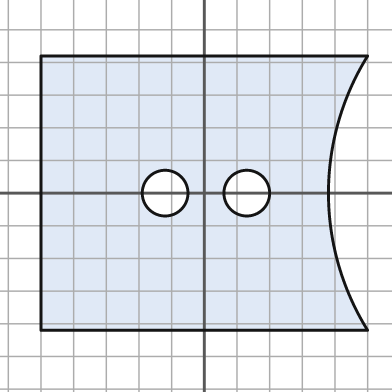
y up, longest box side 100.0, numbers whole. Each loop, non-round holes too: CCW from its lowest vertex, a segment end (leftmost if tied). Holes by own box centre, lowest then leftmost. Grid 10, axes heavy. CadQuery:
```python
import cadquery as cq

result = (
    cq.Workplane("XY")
    .moveTo(-50.0, -42.0)
    .lineTo(50.0, -42.0)
    .threePointArc((38.0, 0.0), (50.0, 42.0))
    .lineTo(-50.0, 42.0)
    .close()
    .moveTo(-12.0, 0.0)
    .circle(7.0)
    .moveTo(13.0, 0.0)
    .circle(7.0)
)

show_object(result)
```